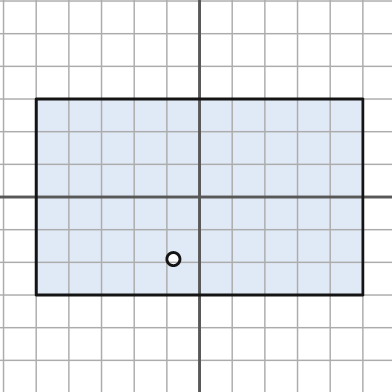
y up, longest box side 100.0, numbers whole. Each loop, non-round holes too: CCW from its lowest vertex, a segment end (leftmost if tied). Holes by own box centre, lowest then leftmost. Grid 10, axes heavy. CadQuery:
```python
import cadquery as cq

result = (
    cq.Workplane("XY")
    .moveTo(-50.0, -30.0)
    .lineTo(50.0, -30.0)
    .lineTo(50.0, 30.0)
    .lineTo(-50.0, 30.0)
    .close()
    .moveTo(-8.0, -19.0)
    .circle(2.0)
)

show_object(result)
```